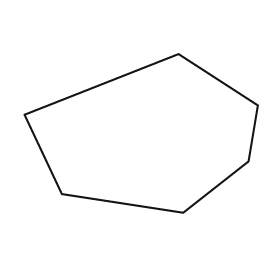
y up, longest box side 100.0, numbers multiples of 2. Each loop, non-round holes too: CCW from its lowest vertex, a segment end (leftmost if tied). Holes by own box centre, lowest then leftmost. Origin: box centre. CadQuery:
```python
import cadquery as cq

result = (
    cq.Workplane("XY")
    .moveTo(18.0, -34.0)
    .lineTo(46.0, -12.0)
    .lineTo(50.0, 12.0)
    .lineTo(16.0, 34.0)
    .lineTo(-50.0, 8.0)
    .lineTo(-34.0, -26.0)
    .close()
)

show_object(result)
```